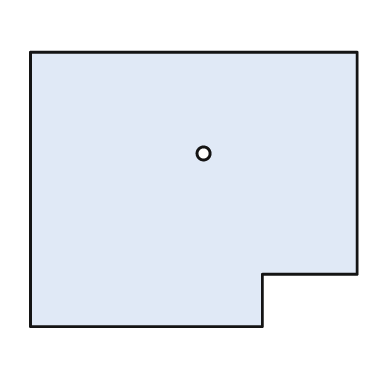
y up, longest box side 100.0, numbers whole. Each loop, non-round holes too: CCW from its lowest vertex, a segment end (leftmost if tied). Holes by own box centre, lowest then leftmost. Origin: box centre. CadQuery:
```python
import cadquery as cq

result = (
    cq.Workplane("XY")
    .moveTo(-50.0, -42.0)
    .lineTo(21.0, -42.0)
    .lineTo(21.0, -26.0)
    .lineTo(50.0, -26.0)
    .lineTo(50.0, 42.0)
    .lineTo(-50.0, 42.0)
    .close()
    .moveTo(3.0, 11.0)
    .circle(2.0)
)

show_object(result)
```